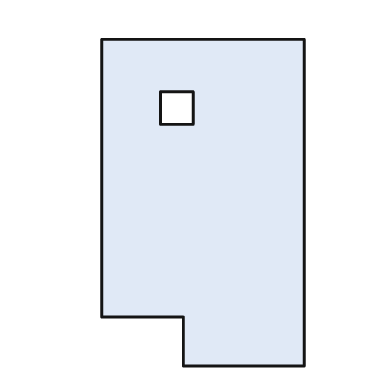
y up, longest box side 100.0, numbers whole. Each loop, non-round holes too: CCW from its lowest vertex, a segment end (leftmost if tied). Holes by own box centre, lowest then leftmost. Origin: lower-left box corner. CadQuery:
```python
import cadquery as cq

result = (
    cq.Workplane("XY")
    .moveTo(25.0, 0.0)
    .lineTo(62.0, 0.0)
    .lineTo(62.0, 100.0)
    .lineTo(0.0, 100.0)
    .lineTo(0.0, 15.0)
    .lineTo(25.0, 15.0)
    .close()
    .moveTo(18.0, 74.0)
    .lineTo(28.0, 74.0)
    .lineTo(28.0, 84.0)
    .lineTo(18.0, 84.0)
    .close()
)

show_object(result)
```